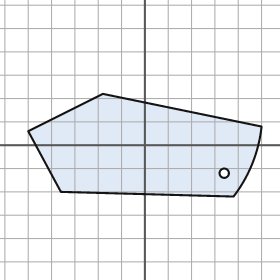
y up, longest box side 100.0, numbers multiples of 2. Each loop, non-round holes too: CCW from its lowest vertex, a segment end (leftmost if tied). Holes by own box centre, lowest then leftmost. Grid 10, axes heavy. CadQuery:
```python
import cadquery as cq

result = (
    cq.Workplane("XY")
    .moveTo(38.0, -22.0)
    .threePointArc((46.0, -8.0), (50.0, 8.0))
    .lineTo(-18.0, 22.0)
    .lineTo(-50.0, 6.0)
    .lineTo(-36.0, -20.0)
    .close()
    .moveTo(34.0, -12.0)
    .circle(2.0)
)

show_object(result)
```